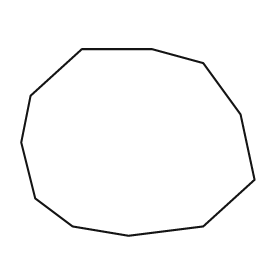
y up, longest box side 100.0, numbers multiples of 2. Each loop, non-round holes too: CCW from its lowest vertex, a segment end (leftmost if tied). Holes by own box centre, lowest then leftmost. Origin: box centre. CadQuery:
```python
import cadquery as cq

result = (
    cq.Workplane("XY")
    .moveTo(-4.0, -40.0)
    .lineTo(28.0, -36.0)
    .lineTo(50.0, -16.0)
    .lineTo(44.0, 12.0)
    .lineTo(28.0, 34.0)
    .lineTo(6.0, 40.0)
    .lineTo(-24.0, 40.0)
    .lineTo(-46.0, 20.0)
    .lineTo(-50.0, 0.0)
    .lineTo(-44.0, -24.0)
    .lineTo(-28.0, -36.0)
    .close()
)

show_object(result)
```